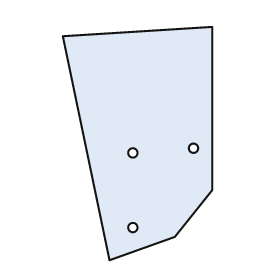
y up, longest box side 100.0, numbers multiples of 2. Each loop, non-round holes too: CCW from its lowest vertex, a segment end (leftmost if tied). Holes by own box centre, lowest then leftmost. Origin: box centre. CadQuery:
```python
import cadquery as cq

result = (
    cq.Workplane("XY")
    .moveTo(-12.0, -50.0)
    .lineTo(16.0, -40.0)
    .lineTo(32.0, -20.0)
    .lineTo(32.0, 50.0)
    .lineTo(-32.0, 46.0)
    .close()
    .moveTo(-2.0, -36.0)
    .circle(2.0)
    .moveTo(-2.0, -4.0)
    .circle(2.0)
    .moveTo(24.0, -2.0)
    .circle(2.0)
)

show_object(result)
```